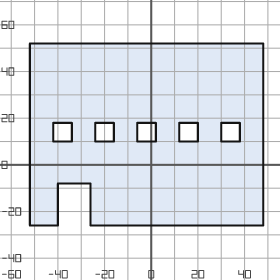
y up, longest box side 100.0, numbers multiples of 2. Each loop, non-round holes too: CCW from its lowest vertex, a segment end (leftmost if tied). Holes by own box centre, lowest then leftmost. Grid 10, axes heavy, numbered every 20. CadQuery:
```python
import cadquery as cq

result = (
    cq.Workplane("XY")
    .moveTo(-52.0, -26.0)
    .lineTo(-40.0, -26.0)
    .lineTo(-40.0, -8.0)
    .lineTo(-26.0, -8.0)
    .lineTo(-26.0, -26.0)
    .lineTo(48.0, -26.0)
    .lineTo(48.0, 52.0)
    .lineTo(-52.0, 52.0)
    .close()
    .moveTo(-42.0, 10.0)
    .lineTo(-34.0, 10.0)
    .lineTo(-34.0, 18.0)
    .lineTo(-42.0, 18.0)
    .close()
    .moveTo(-24.0, 10.0)
    .lineTo(-16.0, 10.0)
    .lineTo(-16.0, 18.0)
    .lineTo(-24.0, 18.0)
    .close()
    .moveTo(-6.0, 10.0)
    .lineTo(2.0, 10.0)
    .lineTo(2.0, 18.0)
    .lineTo(-6.0, 18.0)
    .close()
    .moveTo(12.0, 10.0)
    .lineTo(20.0, 10.0)
    .lineTo(20.0, 18.0)
    .lineTo(12.0, 18.0)
    .close()
    .moveTo(30.0, 10.0)
    .lineTo(38.0, 10.0)
    .lineTo(38.0, 18.0)
    .lineTo(30.0, 18.0)
    .close()
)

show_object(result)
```